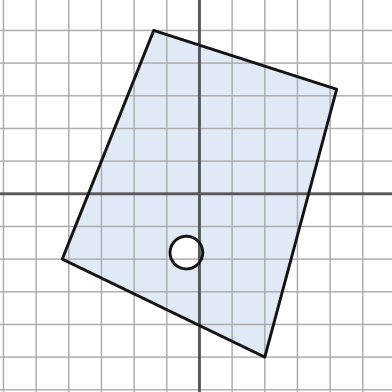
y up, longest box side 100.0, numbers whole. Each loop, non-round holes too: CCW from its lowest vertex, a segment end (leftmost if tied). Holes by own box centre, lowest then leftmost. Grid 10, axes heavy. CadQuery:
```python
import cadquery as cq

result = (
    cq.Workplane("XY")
    .moveTo(20.0, -50.0)
    .lineTo(42.0, 32.0)
    .lineTo(-14.0, 50.0)
    .lineTo(-42.0, -20.0)
    .close()
    .moveTo(-4.0, -18.0)
    .circle(5.0)
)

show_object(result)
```